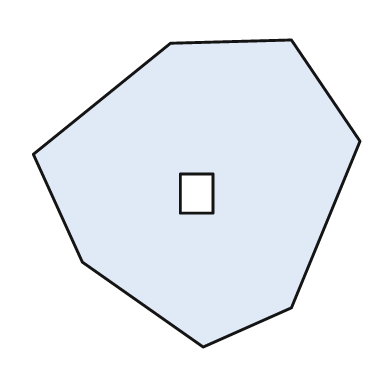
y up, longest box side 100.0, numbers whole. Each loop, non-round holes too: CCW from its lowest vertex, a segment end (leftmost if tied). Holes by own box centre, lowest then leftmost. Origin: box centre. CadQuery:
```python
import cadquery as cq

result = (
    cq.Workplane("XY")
    .moveTo(2.0, -47.0)
    .lineTo(29.0, -35.0)
    .lineTo(50.0, 16.0)
    .lineTo(29.0, 47.0)
    .lineTo(-8.0, 46.0)
    .lineTo(-50.0, 12.0)
    .lineTo(-35.0, -21.0)
    .close()
    .moveTo(-5.0, -6.0)
    .lineTo(5.0, -6.0)
    .lineTo(5.0, 6.0)
    .lineTo(-5.0, 6.0)
    .close()
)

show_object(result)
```